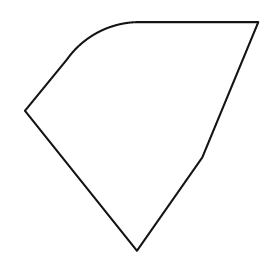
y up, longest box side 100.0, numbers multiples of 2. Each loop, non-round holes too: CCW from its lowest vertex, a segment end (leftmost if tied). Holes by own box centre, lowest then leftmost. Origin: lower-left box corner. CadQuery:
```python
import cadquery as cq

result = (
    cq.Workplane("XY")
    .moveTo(48.0, 0.0)
    .lineTo(76.0, 40.0)
    .lineTo(100.0, 98.0)
    .lineTo(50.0, 98.0)
    .threePointArc((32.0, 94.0), (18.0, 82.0))
    .lineTo(0.0, 60.0)
    .close()
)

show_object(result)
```